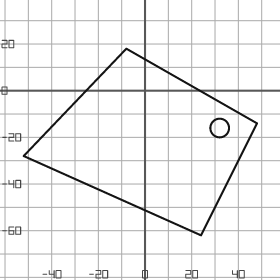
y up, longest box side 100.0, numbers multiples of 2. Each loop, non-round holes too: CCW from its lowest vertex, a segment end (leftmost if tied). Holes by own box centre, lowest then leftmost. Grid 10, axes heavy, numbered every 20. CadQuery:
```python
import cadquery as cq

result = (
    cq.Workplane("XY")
    .moveTo(24.0, -62.0)
    .lineTo(48.0, -14.0)
    .lineTo(-8.0, 18.0)
    .lineTo(-52.0, -28.0)
    .close()
    .moveTo(32.0, -16.0)
    .circle(4.0)
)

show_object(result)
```